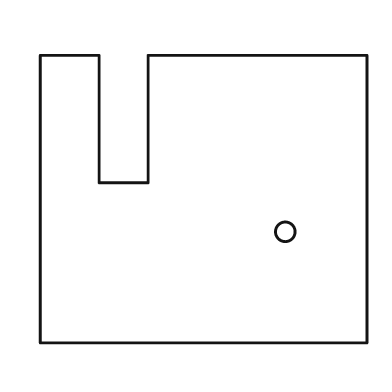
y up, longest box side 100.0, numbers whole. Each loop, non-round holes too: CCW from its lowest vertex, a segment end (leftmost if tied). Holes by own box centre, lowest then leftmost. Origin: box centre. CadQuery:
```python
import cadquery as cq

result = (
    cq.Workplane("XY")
    .moveTo(-50.0, -44.0)
    .lineTo(50.0, -44.0)
    .lineTo(50.0, 44.0)
    .lineTo(-17.0, 44.0)
    .lineTo(-17.0, 5.0)
    .lineTo(-32.0, 5.0)
    .lineTo(-32.0, 44.0)
    .lineTo(-50.0, 44.0)
    .close()
    .moveTo(25.0, -10.0)
    .circle(3.0)
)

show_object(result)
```